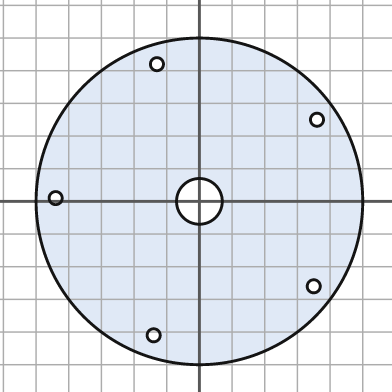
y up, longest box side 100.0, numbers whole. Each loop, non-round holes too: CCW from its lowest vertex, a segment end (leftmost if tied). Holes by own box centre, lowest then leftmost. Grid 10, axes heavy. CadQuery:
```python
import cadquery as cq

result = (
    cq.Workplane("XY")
    .moveTo(0.0, 0.0)
    .circle(50.0)
    .moveTo(-14.0, -41.0)
    .circle(2.0)
    .moveTo(35.0, -26.0)
    .circle(2.0)
    .moveTo(0.0, 0.0)
    .circle(7.0)
    .moveTo(-44.0, 1.0)
    .circle(2.0)
    .moveTo(36.0, 25.0)
    .circle(2.0)
    .moveTo(-13.0, 42.0)
    .circle(2.0)
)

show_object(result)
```